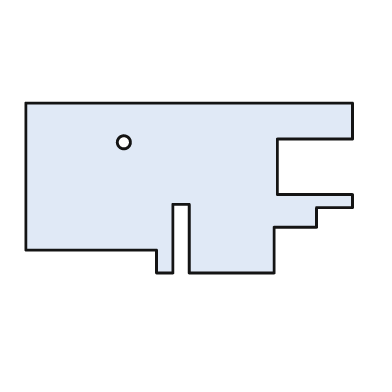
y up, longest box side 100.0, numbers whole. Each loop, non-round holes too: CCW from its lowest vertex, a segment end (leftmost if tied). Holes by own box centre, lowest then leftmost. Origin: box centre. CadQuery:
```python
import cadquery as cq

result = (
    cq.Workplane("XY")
    .moveTo(-10.0, -26.0)
    .lineTo(-5.0, -26.0)
    .lineTo(-5.0, -5.0)
    .lineTo(0.0, -5.0)
    .lineTo(0.0, -26.0)
    .lineTo(26.0, -26.0)
    .lineTo(26.0, -12.0)
    .lineTo(39.0, -12.0)
    .lineTo(39.0, -6.0)
    .lineTo(50.0, -6.0)
    .lineTo(50.0, -2.0)
    .lineTo(27.0, -2.0)
    .lineTo(27.0, 15.0)
    .lineTo(50.0, 15.0)
    .lineTo(50.0, 26.0)
    .lineTo(-50.0, 26.0)
    .lineTo(-50.0, -19.0)
    .lineTo(-10.0, -19.0)
    .close()
    .moveTo(-20.0, 14.0)
    .circle(2.0)
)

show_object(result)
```